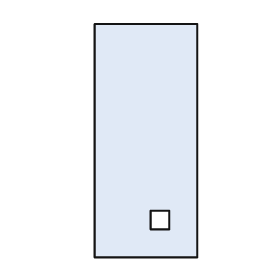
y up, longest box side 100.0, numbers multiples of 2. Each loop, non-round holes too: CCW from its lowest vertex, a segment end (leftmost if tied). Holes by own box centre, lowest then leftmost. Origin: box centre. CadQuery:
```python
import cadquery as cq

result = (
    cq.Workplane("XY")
    .moveTo(-22.0, -50.0)
    .lineTo(22.0, -50.0)
    .lineTo(22.0, 50.0)
    .lineTo(-22.0, 50.0)
    .close()
    .moveTo(2.0, -38.0)
    .lineTo(10.0, -38.0)
    .lineTo(10.0, -30.0)
    .lineTo(2.0, -30.0)
    .close()
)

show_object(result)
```